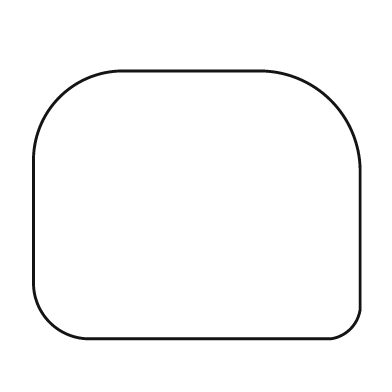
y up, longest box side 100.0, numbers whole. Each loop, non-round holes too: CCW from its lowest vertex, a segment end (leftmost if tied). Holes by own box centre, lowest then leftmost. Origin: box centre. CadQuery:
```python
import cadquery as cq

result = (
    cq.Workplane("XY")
    .moveTo(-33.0, -41.0)
    .lineTo(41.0, -41.0)
    .threePointArc((47.0, -38.0), (50.0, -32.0))
    .lineTo(50.0, 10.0)
    .threePointArc((41.0, 32.0), (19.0, 41.0))
    .lineTo(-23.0, 41.0)
    .threePointArc((-42.0, 33.0), (-50.0, 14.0))
    .lineTo(-50.0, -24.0)
    .threePointArc((-45.0, -36.0), (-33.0, -41.0))
    .close()
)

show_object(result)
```